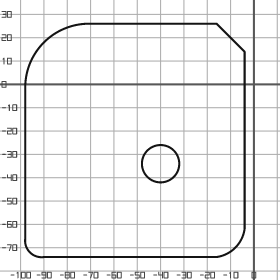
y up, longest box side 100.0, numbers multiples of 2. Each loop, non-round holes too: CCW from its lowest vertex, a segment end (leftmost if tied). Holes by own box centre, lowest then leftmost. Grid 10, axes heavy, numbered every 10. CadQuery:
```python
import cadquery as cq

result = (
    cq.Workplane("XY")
    .moveTo(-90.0, -74.0)
    .lineTo(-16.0, -74.0)
    .threePointArc((-8.0, -70.0), (-4.0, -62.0))
    .lineTo(-4.0, 14.0)
    .lineTo(-16.0, 26.0)
    .lineTo(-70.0, 26.0)
    .threePointArc((-90.0, 18.0), (-98.0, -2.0))
    .lineTo(-98.0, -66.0)
    .threePointArc((-96.0, -72.0), (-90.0, -74.0))
    .close()
    .moveTo(-40.0, -34.0)
    .circle(8.0)
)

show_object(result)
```